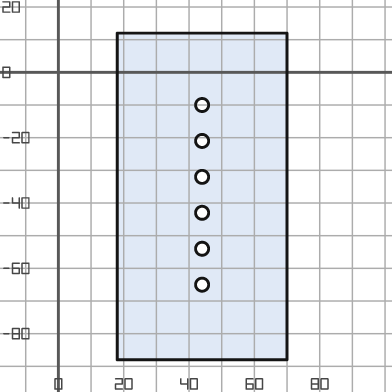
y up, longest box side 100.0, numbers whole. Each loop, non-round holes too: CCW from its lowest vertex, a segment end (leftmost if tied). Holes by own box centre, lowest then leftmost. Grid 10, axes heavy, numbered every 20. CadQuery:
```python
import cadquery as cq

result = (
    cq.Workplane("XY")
    .moveTo(18.0, -88.0)
    .lineTo(70.0, -88.0)
    .lineTo(70.0, 12.0)
    .lineTo(18.0, 12.0)
    .close()
    .moveTo(44.0, -65.0)
    .circle(2.0)
    .moveTo(44.0, -54.0)
    .circle(2.0)
    .moveTo(44.0, -43.0)
    .circle(2.0)
    .moveTo(44.0, -32.0)
    .circle(2.0)
    .moveTo(44.0, -21.0)
    .circle(2.0)
    .moveTo(44.0, -10.0)
    .circle(2.0)
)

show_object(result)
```